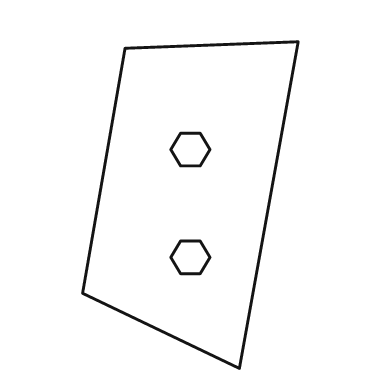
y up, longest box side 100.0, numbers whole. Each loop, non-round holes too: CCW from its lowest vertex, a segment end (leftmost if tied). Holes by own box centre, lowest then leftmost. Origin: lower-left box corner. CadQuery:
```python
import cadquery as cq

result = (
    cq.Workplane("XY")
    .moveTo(48.0, 0.0)
    .lineTo(66.0, 100.0)
    .lineTo(13.0, 98.0)
    .lineTo(0.0, 23.0)
    .close()
    .moveTo(30.0, 29.0)
    .lineTo(36.0, 29.0)
    .lineTo(39.0, 34.0)
    .lineTo(36.0, 39.0)
    .lineTo(30.0, 39.0)
    .lineTo(27.0, 34.0)
    .close()
    .moveTo(30.0, 62.0)
    .lineTo(36.0, 62.0)
    .lineTo(39.0, 67.0)
    .lineTo(36.0, 72.0)
    .lineTo(30.0, 72.0)
    .lineTo(27.0, 67.0)
    .close()
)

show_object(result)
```